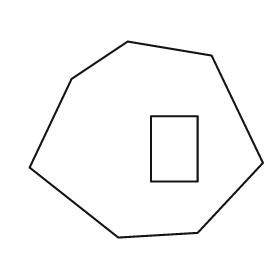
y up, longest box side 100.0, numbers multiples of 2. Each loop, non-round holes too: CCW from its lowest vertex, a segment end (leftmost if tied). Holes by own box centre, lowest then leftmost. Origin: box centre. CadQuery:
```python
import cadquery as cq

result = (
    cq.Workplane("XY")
    .moveTo(-12.0, -42.0)
    .lineTo(22.0, -40.0)
    .lineTo(50.0, -10.0)
    .lineTo(28.0, 36.0)
    .lineTo(-8.0, 42.0)
    .lineTo(-32.0, 26.0)
    .lineTo(-50.0, -12.0)
    .close()
    .moveTo(2.0, -18.0)
    .lineTo(22.0, -18.0)
    .lineTo(22.0, 10.0)
    .lineTo(2.0, 10.0)
    .close()
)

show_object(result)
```